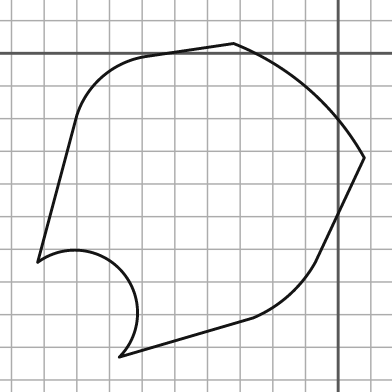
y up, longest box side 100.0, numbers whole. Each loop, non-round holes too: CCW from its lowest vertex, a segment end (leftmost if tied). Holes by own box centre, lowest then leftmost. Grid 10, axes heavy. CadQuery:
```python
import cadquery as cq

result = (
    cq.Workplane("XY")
    .moveTo(-67.0, -93.0)
    .lineTo(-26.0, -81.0)
    .threePointArc((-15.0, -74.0), (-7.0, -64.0))
    .lineTo(8.0, -32.0)
    .threePointArc((-9.0, -11.0), (-32.0, 3.0))
    .lineTo(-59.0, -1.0)
    .threePointArc((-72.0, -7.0), (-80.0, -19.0))
    .lineTo(-92.0, -64.0)
    .threePointArc((-66.0, -67.0), (-67.0, -93.0))
    .close()
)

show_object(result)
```